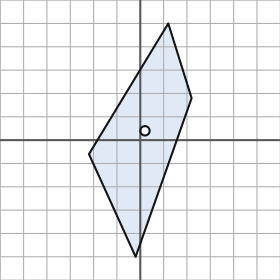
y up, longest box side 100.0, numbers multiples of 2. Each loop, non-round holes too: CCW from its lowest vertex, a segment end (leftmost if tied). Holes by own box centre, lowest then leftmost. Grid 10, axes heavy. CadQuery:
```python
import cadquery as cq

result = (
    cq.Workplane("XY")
    .moveTo(-2.0, -50.0)
    .lineTo(22.0, 18.0)
    .lineTo(12.0, 50.0)
    .lineTo(-22.0, -6.0)
    .close()
    .moveTo(2.0, 4.0)
    .circle(2.0)
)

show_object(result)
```